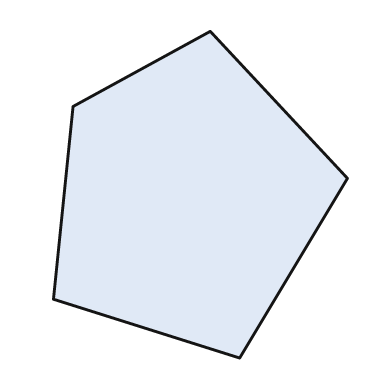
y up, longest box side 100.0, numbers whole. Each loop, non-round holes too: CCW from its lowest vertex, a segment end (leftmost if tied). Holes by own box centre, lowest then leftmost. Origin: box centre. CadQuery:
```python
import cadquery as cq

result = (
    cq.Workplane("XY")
    .moveTo(12.0, -50.0)
    .lineTo(45.0, 5.0)
    .lineTo(3.0, 50.0)
    .lineTo(-39.0, 27.0)
    .lineTo(-45.0, -32.0)
    .close()
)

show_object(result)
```